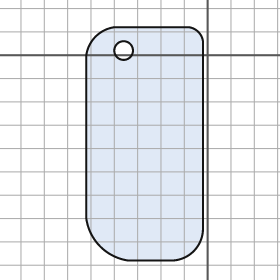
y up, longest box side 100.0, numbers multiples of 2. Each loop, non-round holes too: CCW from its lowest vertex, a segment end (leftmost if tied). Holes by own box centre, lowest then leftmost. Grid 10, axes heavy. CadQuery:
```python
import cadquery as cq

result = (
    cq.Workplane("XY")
    .moveTo(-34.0, -88.0)
    .lineTo(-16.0, -88.0)
    .threePointArc((-6.0, -84.0), (-2.0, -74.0))
    .lineTo(-2.0, 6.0)
    .threePointArc((-4.0, 10.0), (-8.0, 12.0))
    .lineTo(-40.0, 12.0)
    .threePointArc((-48.0, 8.0), (-52.0, 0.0))
    .lineTo(-52.0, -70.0)
    .threePointArc((-46.0, -82.0), (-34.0, -88.0))
    .close()
    .moveTo(-36.0, 2.0)
    .circle(4.0)
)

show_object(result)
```